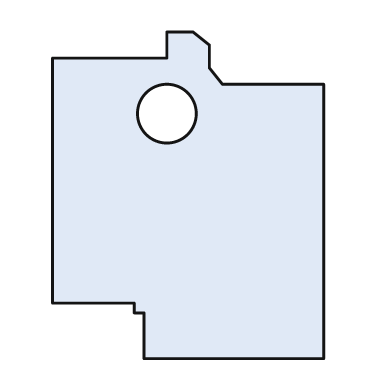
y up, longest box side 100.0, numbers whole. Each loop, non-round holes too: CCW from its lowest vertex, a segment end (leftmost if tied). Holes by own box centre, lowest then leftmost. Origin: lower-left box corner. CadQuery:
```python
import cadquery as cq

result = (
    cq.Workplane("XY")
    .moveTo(28.0, 0.0)
    .lineTo(83.0, 0.0)
    .lineTo(83.0, 84.0)
    .lineTo(52.0, 84.0)
    .lineTo(48.0, 89.0)
    .lineTo(48.0, 96.0)
    .lineTo(43.0, 100.0)
    .lineTo(35.0, 100.0)
    .lineTo(35.0, 92.0)
    .lineTo(0.0, 92.0)
    .lineTo(0.0, 17.0)
    .lineTo(25.0, 17.0)
    .lineTo(25.0, 14.0)
    .lineTo(28.0, 14.0)
    .close()
    .moveTo(35.0, 75.0)
    .circle(9.0)
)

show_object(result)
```